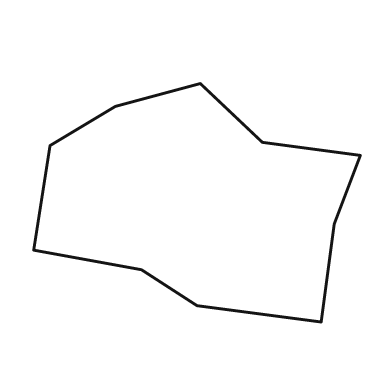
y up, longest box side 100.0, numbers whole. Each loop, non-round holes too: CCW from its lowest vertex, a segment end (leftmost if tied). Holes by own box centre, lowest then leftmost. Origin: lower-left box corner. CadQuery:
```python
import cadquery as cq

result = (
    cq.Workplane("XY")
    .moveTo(88.0, 0.0)
    .lineTo(92.0, 30.0)
    .lineTo(100.0, 51.0)
    .lineTo(70.0, 55.0)
    .lineTo(51.0, 73.0)
    .lineTo(25.0, 66.0)
    .lineTo(5.0, 54.0)
    .lineTo(0.0, 22.0)
    .lineTo(33.0, 16.0)
    .lineTo(50.0, 5.0)
    .close()
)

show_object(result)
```